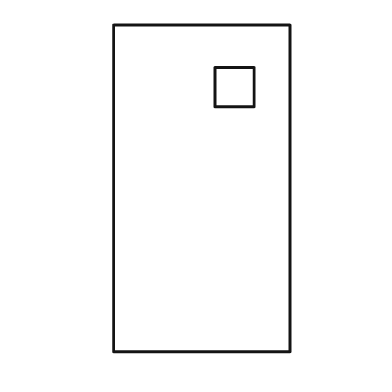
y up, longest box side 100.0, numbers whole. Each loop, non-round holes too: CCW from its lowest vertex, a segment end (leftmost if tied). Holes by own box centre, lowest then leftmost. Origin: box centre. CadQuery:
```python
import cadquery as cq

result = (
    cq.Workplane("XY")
    .moveTo(-27.0, -50.0)
    .lineTo(27.0, -50.0)
    .lineTo(27.0, 50.0)
    .lineTo(-27.0, 50.0)
    .close()
    .moveTo(4.0, 25.0)
    .lineTo(16.0, 25.0)
    .lineTo(16.0, 37.0)
    .lineTo(4.0, 37.0)
    .close()
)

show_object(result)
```